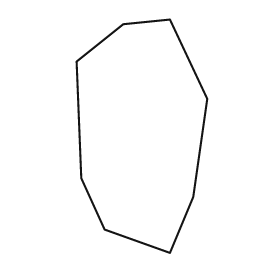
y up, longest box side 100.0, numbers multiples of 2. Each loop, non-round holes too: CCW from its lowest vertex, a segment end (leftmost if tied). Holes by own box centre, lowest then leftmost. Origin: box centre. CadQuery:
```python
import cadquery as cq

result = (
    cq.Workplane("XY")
    .moveTo(12.0, -50.0)
    .lineTo(22.0, -26.0)
    .lineTo(28.0, 16.0)
    .lineTo(12.0, 50.0)
    .lineTo(-8.0, 48.0)
    .lineTo(-28.0, 32.0)
    .lineTo(-26.0, -18.0)
    .lineTo(-16.0, -40.0)
    .close()
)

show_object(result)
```